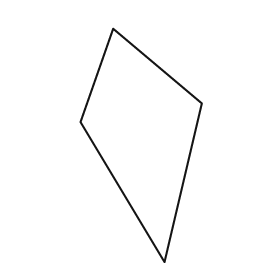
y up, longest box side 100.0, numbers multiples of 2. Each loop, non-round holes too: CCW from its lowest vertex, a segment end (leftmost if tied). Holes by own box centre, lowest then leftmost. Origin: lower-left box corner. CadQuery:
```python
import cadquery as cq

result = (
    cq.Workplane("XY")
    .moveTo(36.0, 0.0)
    .lineTo(52.0, 68.0)
    .lineTo(14.0, 100.0)
    .lineTo(0.0, 60.0)
    .close()
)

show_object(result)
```